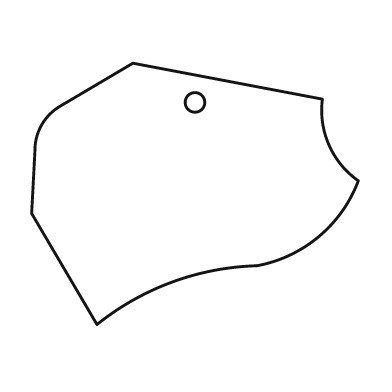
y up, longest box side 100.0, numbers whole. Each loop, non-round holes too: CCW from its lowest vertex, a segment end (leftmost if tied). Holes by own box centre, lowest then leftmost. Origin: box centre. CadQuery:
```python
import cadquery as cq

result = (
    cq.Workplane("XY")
    .moveTo(-30.0, -40.0)
    .threePointArc((-7.0, -27.0), (19.0, -22.0))
    .threePointArc((38.0, -13.0), (50.0, 4.0))
    .threePointArc((41.0, 15.0), (39.0, 29.0))
    .lineTo(-19.0, 40.0)
    .lineTo(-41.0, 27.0)
    .threePointArc((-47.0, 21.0), (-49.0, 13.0))
    .lineTo(-50.0, -6.0)
    .close()
    .moveTo(0.0, 28.0)
    .circle(3.0)
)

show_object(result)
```